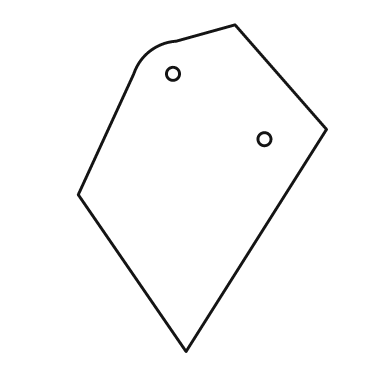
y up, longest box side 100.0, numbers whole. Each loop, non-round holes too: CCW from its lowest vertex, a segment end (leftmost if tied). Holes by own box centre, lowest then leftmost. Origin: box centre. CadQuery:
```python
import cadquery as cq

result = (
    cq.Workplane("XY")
    .moveTo(-5.0, -50.0)
    .lineTo(38.0, 18.0)
    .lineTo(10.0, 50.0)
    .lineTo(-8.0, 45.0)
    .threePointArc((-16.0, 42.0), (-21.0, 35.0))
    .lineTo(-38.0, -2.0)
    .close()
    .moveTo(19.0, 15.0)
    .circle(2.0)
    .moveTo(-9.0, 35.0)
    .circle(2.0)
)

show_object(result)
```